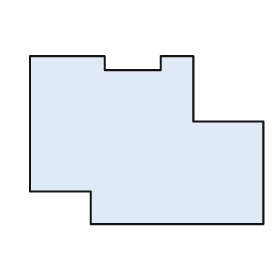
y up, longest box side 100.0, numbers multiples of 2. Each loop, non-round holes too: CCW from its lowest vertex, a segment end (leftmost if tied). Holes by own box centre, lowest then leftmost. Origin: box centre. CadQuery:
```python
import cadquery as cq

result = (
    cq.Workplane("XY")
    .moveTo(-24.0, -36.0)
    .lineTo(50.0, -36.0)
    .lineTo(50.0, 8.0)
    .lineTo(20.0, 8.0)
    .lineTo(20.0, 36.0)
    .lineTo(6.0, 36.0)
    .lineTo(6.0, 30.0)
    .lineTo(-18.0, 30.0)
    .lineTo(-18.0, 36.0)
    .lineTo(-50.0, 36.0)
    .lineTo(-50.0, -22.0)
    .lineTo(-24.0, -22.0)
    .close()
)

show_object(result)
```